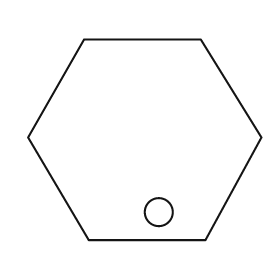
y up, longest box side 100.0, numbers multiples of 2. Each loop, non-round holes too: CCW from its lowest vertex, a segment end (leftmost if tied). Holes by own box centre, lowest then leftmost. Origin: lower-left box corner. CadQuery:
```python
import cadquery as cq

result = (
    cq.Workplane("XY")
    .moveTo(26.0, 0.0)
    .lineTo(76.0, 0.0)
    .lineTo(100.0, 44.0)
    .lineTo(74.0, 86.0)
    .lineTo(24.0, 86.0)
    .lineTo(0.0, 44.0)
    .close()
    .moveTo(56.0, 12.0)
    .circle(6.0)
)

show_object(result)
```